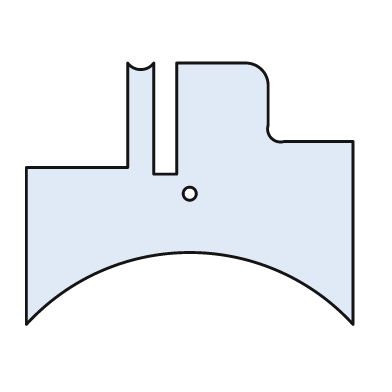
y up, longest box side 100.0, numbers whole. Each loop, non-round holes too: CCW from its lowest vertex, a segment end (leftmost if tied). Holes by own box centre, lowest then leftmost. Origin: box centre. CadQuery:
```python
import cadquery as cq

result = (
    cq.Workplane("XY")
    .moveTo(-50.0, -40.0)
    .threePointArc((0.0, -18.0), (50.0, -40.0))
    .lineTo(50.0, 16.0)
    .lineTo(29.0, 16.0)
    .threePointArc((25.0, 17.0), (24.0, 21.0))
    .lineTo(24.0, 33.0)
    .threePointArc((22.0, 38.0), (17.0, 40.0))
    .lineTo(-4.0, 40.0)
    .lineTo(-4.0, 6.0)
    .lineTo(-11.0, 6.0)
    .lineTo(-11.0, 40.0)
    .threePointArc((-15.0, 38.0), (-19.0, 40.0))
    .lineTo(-19.0, 8.0)
    .lineTo(-50.0, 8.0)
    .close()
    .moveTo(0.0, 0.0)
    .circle(2.0)
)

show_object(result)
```